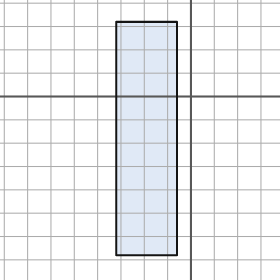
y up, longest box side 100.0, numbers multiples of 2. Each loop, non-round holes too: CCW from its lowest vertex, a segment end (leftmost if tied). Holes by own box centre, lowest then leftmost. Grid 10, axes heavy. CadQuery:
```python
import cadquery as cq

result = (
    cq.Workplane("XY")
    .moveTo(-32.0, -68.0)
    .lineTo(-6.0, -68.0)
    .lineTo(-6.0, 32.0)
    .lineTo(-32.0, 32.0)
    .close()
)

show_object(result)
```